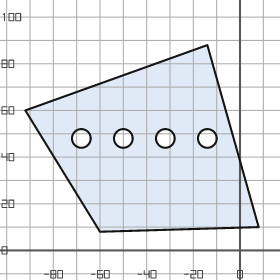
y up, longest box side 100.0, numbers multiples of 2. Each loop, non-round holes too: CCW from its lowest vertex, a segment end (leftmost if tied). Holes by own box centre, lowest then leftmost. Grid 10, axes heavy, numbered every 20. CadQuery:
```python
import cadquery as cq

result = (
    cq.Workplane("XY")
    .moveTo(-60.0, 8.0)
    .lineTo(8.0, 10.0)
    .lineTo(-14.0, 88.0)
    .lineTo(-92.0, 60.0)
    .close()
    .moveTo(-68.0, 48.0)
    .circle(4.0)
    .moveTo(-50.0, 48.0)
    .circle(4.0)
    .moveTo(-32.0, 48.0)
    .circle(4.0)
    .moveTo(-14.0, 48.0)
    .circle(4.0)
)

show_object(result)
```